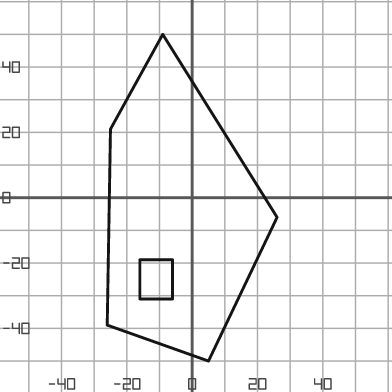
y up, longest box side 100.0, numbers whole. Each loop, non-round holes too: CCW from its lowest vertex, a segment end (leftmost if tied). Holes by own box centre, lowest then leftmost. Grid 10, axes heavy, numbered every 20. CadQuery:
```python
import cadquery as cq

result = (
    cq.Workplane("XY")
    .moveTo(5.0, -50.0)
    .lineTo(26.0, -6.0)
    .lineTo(-9.0, 50.0)
    .lineTo(-25.0, 21.0)
    .lineTo(-26.0, -39.0)
    .close()
    .moveTo(-16.0, -31.0)
    .lineTo(-6.0, -31.0)
    .lineTo(-6.0, -19.0)
    .lineTo(-16.0, -19.0)
    .close()
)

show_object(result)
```